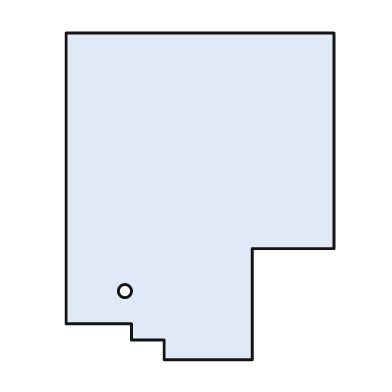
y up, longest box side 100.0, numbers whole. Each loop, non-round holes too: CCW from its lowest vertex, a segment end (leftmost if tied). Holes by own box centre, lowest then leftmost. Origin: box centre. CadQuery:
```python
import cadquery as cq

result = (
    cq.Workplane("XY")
    .moveTo(-11.0, -50.0)
    .lineTo(16.0, -50.0)
    .lineTo(16.0, -16.0)
    .lineTo(41.0, -16.0)
    .lineTo(41.0, 50.0)
    .lineTo(-41.0, 50.0)
    .lineTo(-41.0, -39.0)
    .lineTo(-21.0, -39.0)
    .lineTo(-21.0, -44.0)
    .lineTo(-11.0, -44.0)
    .close()
    .moveTo(-23.0, -29.0)
    .circle(2.0)
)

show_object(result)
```